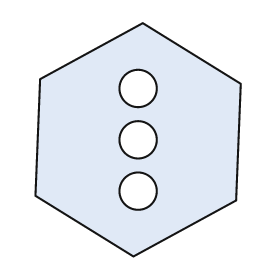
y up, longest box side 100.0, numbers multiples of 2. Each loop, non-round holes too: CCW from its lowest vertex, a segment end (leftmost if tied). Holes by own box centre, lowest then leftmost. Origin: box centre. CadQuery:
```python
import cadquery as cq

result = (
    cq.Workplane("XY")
    .moveTo(-2.0, -50.0)
    .lineTo(42.0, -26.0)
    .lineTo(44.0, 24.0)
    .lineTo(2.0, 50.0)
    .lineTo(-42.0, 26.0)
    .lineTo(-44.0, -24.0)
    .close()
    .moveTo(0.0, -22.0)
    .circle(8.0)
    .moveTo(0.0, 0.0)
    .circle(8.0)
    .moveTo(0.0, 22.0)
    .circle(8.0)
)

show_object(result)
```